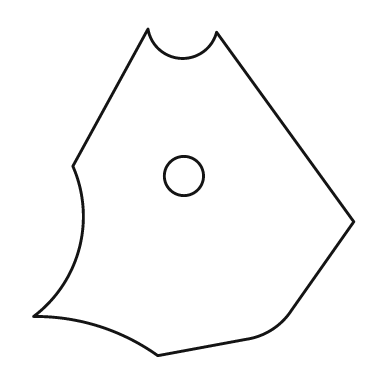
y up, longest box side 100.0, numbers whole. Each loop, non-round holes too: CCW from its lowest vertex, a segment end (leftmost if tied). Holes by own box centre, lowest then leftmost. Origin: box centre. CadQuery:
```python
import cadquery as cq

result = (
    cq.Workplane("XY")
    .moveTo(-11.0, -50.0)
    .lineTo(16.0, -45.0)
    .threePointArc((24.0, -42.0), (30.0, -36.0))
    .lineTo(49.0, -9.0)
    .lineTo(7.0, 49.0)
    .threePointArc((-4.0, 41.0), (-14.0, 50.0))
    .lineTo(-37.0, 8.0)
    .threePointArc((-35.0, -17.0), (-49.0, -38.0))
    .threePointArc((-29.0, -41.0), (-11.0, -50.0))
    .close()
    .moveTo(-3.0, 5.0)
    .circle(6.0)
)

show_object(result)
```